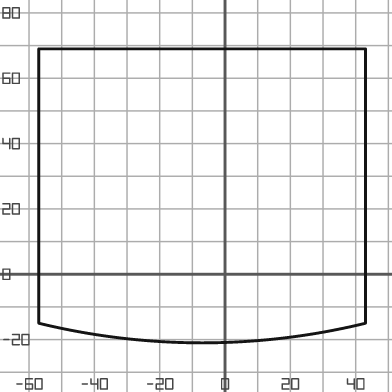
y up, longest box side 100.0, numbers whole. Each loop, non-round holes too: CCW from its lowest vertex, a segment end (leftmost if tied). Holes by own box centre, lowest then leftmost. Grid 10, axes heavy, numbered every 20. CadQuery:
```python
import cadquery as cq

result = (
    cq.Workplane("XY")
    .moveTo(-57.0, -15.0)
    .threePointArc((-7.0, -21.0), (43.0, -15.0))
    .lineTo(43.0, 69.0)
    .lineTo(-57.0, 69.0)
    .close()
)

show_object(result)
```